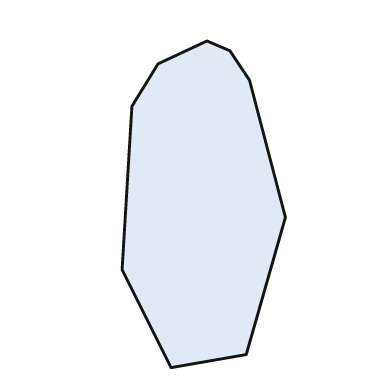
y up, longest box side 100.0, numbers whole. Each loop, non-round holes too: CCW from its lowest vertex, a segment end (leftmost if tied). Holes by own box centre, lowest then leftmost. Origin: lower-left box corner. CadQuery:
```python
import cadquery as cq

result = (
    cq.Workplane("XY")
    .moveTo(15.0, 0.0)
    .lineTo(38.0, 4.0)
    .lineTo(50.0, 46.0)
    .lineTo(39.0, 88.0)
    .lineTo(33.0, 97.0)
    .lineTo(26.0, 100.0)
    .lineTo(11.0, 93.0)
    .lineTo(3.0, 80.0)
    .lineTo(0.0, 30.0)
    .close()
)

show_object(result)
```